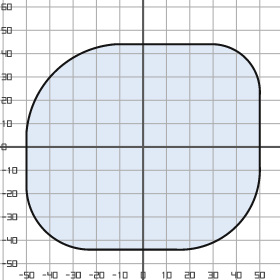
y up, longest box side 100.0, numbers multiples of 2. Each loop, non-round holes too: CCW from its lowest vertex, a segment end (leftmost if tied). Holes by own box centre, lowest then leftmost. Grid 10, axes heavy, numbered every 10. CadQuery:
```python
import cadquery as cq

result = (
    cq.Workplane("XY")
    .moveTo(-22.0, -44.0)
    .lineTo(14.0, -44.0)
    .threePointArc((40.0, -34.0), (50.0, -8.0))
    .lineTo(50.0, 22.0)
    .threePointArc((44.0, 38.0), (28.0, 44.0))
    .lineTo(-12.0, 44.0)
    .threePointArc((-38.0, 32.0), (-50.0, 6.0))
    .lineTo(-50.0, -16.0)
    .threePointArc((-42.0, -36.0), (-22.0, -44.0))
    .close()
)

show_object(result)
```